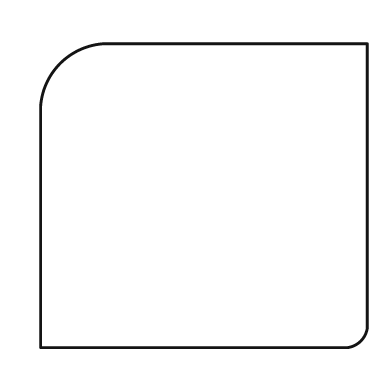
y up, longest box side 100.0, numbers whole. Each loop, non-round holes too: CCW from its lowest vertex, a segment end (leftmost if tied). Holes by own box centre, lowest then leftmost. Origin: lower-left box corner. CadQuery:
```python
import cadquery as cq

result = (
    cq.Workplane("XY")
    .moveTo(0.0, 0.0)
    .lineTo(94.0, 0.0)
    .threePointArc((98.0, 2.0), (100.0, 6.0))
    .lineTo(100.0, 93.0)
    .lineTo(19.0, 93.0)
    .threePointArc((6.0, 87.0), (0.0, 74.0))
    .close()
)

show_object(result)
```